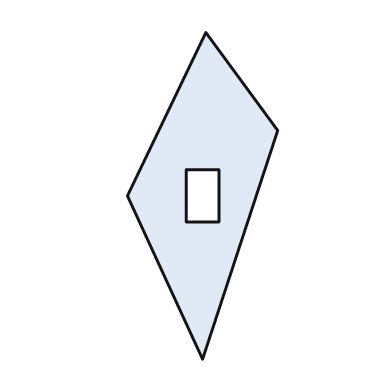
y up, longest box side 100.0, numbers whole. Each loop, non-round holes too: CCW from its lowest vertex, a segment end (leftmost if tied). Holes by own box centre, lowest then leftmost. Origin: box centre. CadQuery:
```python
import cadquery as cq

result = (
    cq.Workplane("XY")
    .moveTo(0.0, -50.0)
    .lineTo(23.0, 20.0)
    .lineTo(1.0, 50.0)
    .lineTo(-23.0, 0.0)
    .close()
    .moveTo(-5.0, -8.0)
    .lineTo(5.0, -8.0)
    .lineTo(5.0, 8.0)
    .lineTo(-5.0, 8.0)
    .close()
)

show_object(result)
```